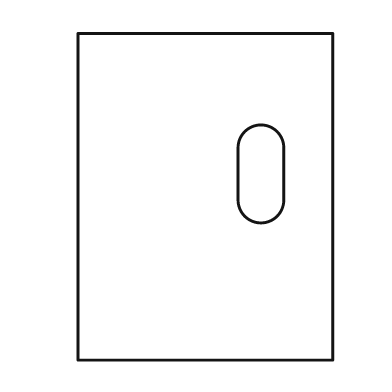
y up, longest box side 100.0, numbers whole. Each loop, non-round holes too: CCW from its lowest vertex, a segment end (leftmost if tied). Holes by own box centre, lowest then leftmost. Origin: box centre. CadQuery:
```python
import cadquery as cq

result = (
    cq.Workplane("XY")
    .moveTo(-39.0, -50.0)
    .lineTo(39.0, -50.0)
    .lineTo(39.0, 50.0)
    .lineTo(-39.0, 50.0)
    .close()
    .moveTo(10.0, -1.0)
    .threePointArc((17.0, -8.0), (24.0, -1.0))
    .lineTo(24.0, 15.0)
    .threePointArc((17.0, 22.0), (10.0, 15.0))
    .close()
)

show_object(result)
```